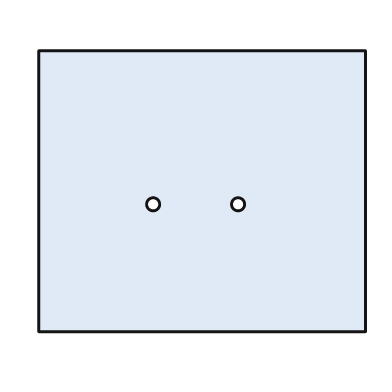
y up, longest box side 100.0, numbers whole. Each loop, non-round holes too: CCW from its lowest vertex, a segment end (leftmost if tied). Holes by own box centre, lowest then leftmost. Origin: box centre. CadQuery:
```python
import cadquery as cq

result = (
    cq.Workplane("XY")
    .moveTo(-50.0, -43.0)
    .lineTo(50.0, -43.0)
    .lineTo(50.0, 43.0)
    .lineTo(-50.0, 43.0)
    .close()
    .moveTo(-15.0, -4.0)
    .circle(2.0)
    .moveTo(11.0, -4.0)
    .circle(2.0)
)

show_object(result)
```